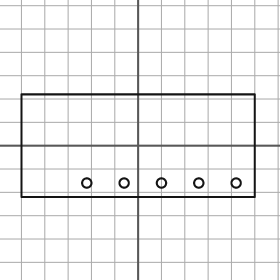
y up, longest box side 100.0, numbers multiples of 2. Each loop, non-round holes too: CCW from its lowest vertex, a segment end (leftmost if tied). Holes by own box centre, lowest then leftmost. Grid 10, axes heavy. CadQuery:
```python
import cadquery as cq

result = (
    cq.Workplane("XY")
    .moveTo(-50.0, -22.0)
    .lineTo(50.0, -22.0)
    .lineTo(50.0, 22.0)
    .lineTo(-50.0, 22.0)
    .close()
    .moveTo(-22.0, -16.0)
    .circle(2.0)
    .moveTo(-6.0, -16.0)
    .circle(2.0)
    .moveTo(10.0, -16.0)
    .circle(2.0)
    .moveTo(26.0, -16.0)
    .circle(2.0)
    .moveTo(42.0, -16.0)
    .circle(2.0)
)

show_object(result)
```